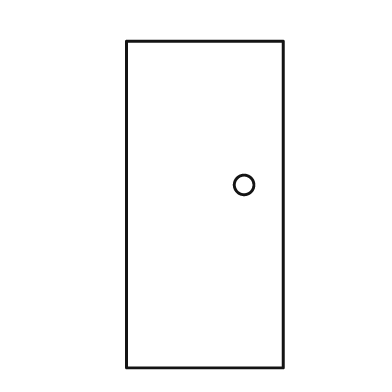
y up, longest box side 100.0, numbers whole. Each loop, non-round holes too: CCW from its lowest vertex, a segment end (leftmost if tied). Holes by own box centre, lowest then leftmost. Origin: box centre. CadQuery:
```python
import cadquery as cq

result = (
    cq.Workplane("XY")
    .moveTo(-24.0, -50.0)
    .lineTo(24.0, -50.0)
    .lineTo(24.0, 50.0)
    .lineTo(-24.0, 50.0)
    .close()
    .moveTo(12.0, 6.0)
    .circle(3.0)
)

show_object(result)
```